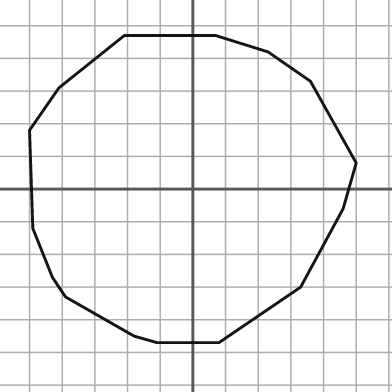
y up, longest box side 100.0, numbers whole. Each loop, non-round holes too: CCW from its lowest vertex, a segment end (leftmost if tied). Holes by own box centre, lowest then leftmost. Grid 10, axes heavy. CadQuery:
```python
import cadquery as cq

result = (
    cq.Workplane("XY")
    .moveTo(-11.0, -47.0)
    .lineTo(8.0, -47.0)
    .lineTo(33.0, -30.0)
    .lineTo(46.0, -6.0)
    .lineTo(50.0, 8.0)
    .lineTo(36.0, 33.0)
    .lineTo(23.0, 42.0)
    .lineTo(7.0, 47.0)
    .lineTo(-21.0, 47.0)
    .lineTo(-41.0, 31.0)
    .lineTo(-50.0, 18.0)
    .lineTo(-49.0, -12.0)
    .lineTo(-43.0, -27.0)
    .lineTo(-39.0, -33.0)
    .lineTo(-18.0, -45.0)
    .close()
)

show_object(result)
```